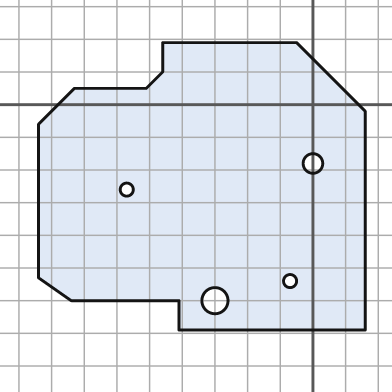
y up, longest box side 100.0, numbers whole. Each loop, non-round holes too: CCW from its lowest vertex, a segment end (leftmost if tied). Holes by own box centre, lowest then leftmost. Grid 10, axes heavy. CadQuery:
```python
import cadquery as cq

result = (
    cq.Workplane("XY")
    .moveTo(-41.0, -69.0)
    .lineTo(16.0, -69.0)
    .lineTo(16.0, -2.0)
    .lineTo(-5.0, 19.0)
    .lineTo(-46.0, 19.0)
    .lineTo(-46.0, 10.0)
    .lineTo(-51.0, 5.0)
    .lineTo(-73.0, 5.0)
    .lineTo(-84.0, -6.0)
    .lineTo(-84.0, -53.0)
    .lineTo(-74.0, -60.0)
    .lineTo(-41.0, -60.0)
    .close()
    .moveTo(-30.0, -60.0)
    .circle(4.0)
    .moveTo(-7.0, -54.0)
    .circle(2.0)
    .moveTo(-57.0, -26.0)
    .circle(2.0)
    .moveTo(0.0, -18.0)
    .circle(3.0)
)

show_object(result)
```